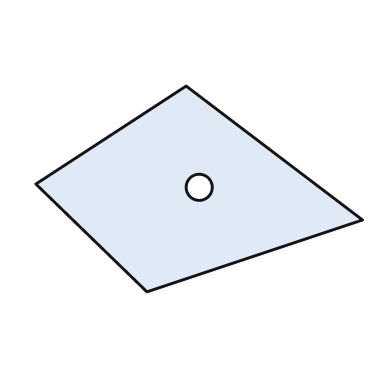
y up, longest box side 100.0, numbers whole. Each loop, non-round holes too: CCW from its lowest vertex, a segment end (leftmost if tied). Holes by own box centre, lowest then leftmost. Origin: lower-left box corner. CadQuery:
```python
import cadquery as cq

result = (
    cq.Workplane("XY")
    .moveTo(34.0, 0.0)
    .lineTo(100.0, 22.0)
    .lineTo(46.0, 63.0)
    .lineTo(0.0, 33.0)
    .close()
    .moveTo(50.0, 32.0)
    .circle(4.0)
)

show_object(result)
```